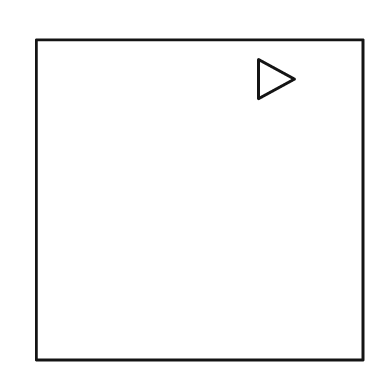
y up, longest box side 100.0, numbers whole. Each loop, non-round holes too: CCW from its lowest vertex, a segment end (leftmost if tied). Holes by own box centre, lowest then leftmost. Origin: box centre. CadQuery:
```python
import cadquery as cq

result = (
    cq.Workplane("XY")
    .moveTo(-50.0, -49.0)
    .lineTo(50.0, -49.0)
    .lineTo(50.0, 49.0)
    .lineTo(-50.0, 49.0)
    .close()
    .moveTo(18.0, 31.0)
    .lineTo(29.0, 37.0)
    .lineTo(18.0, 43.0)
    .close()
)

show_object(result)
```